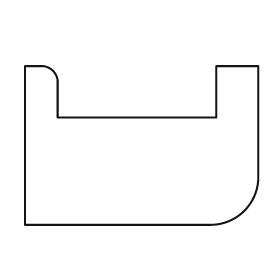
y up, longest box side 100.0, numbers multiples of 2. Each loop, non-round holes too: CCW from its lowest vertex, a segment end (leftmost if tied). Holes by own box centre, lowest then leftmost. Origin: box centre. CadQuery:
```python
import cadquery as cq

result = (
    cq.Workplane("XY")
    .moveTo(-50.0, -34.0)
    .lineTo(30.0, -34.0)
    .threePointArc((44.0, -28.0), (50.0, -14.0))
    .lineTo(50.0, 34.0)
    .lineTo(32.0, 34.0)
    .lineTo(32.0, 12.0)
    .lineTo(-36.0, 12.0)
    .lineTo(-36.0, 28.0)
    .threePointArc((-38.0, 32.0), (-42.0, 34.0))
    .lineTo(-50.0, 34.0)
    .close()
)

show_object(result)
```